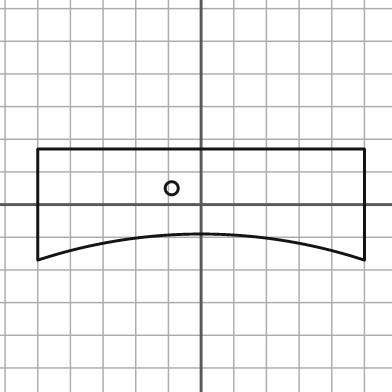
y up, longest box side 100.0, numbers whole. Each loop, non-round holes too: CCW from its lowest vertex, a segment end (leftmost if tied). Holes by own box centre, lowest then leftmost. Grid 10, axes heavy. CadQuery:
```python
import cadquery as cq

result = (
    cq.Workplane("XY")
    .moveTo(-50.0, -17.0)
    .threePointArc((0.0, -9.0), (50.0, -17.0))
    .lineTo(50.0, 17.0)
    .lineTo(-50.0, 17.0)
    .close()
    .moveTo(-9.0, 5.0)
    .circle(2.0)
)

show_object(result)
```